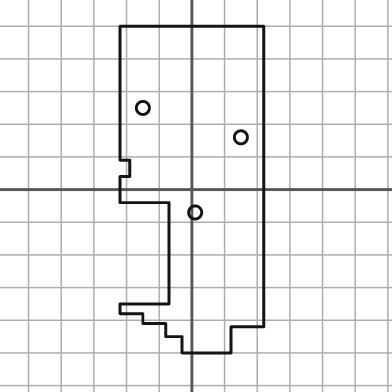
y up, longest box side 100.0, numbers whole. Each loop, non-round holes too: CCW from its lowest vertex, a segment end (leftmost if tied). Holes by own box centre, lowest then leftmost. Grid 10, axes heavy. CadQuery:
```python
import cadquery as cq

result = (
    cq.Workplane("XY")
    .moveTo(-3.0, -50.0)
    .lineTo(12.0, -50.0)
    .lineTo(12.0, -42.0)
    .lineTo(22.0, -42.0)
    .lineTo(22.0, 50.0)
    .lineTo(-22.0, 50.0)
    .lineTo(-22.0, 9.0)
    .lineTo(-19.0, 9.0)
    .lineTo(-19.0, 4.0)
    .lineTo(-22.0, 4.0)
    .lineTo(-22.0, -4.0)
    .lineTo(-7.0, -4.0)
    .lineTo(-7.0, -35.0)
    .lineTo(-22.0, -35.0)
    .lineTo(-22.0, -38.0)
    .lineTo(-15.0, -38.0)
    .lineTo(-15.0, -41.0)
    .lineTo(-8.0, -41.0)
    .lineTo(-8.0, -45.0)
    .lineTo(-3.0, -45.0)
    .close()
    .moveTo(1.0, -7.0)
    .circle(2.0)
    .moveTo(15.0, 16.0)
    .circle(2.0)
    .moveTo(-15.0, 25.0)
    .circle(2.0)
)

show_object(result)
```